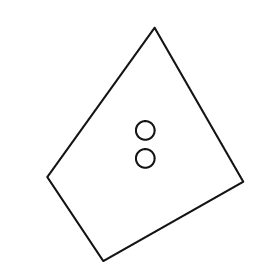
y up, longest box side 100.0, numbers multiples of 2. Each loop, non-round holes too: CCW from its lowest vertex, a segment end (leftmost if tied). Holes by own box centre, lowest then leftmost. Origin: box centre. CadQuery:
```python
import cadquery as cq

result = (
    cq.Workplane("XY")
    .moveTo(-18.0, -50.0)
    .lineTo(42.0, -16.0)
    .lineTo(4.0, 50.0)
    .lineTo(-42.0, -14.0)
    .close()
    .moveTo(0.0, -6.0)
    .circle(4.0)
    .moveTo(0.0, 6.0)
    .circle(4.0)
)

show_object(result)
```